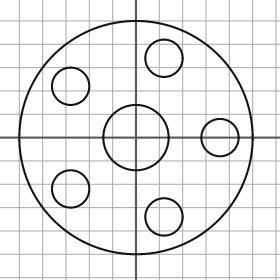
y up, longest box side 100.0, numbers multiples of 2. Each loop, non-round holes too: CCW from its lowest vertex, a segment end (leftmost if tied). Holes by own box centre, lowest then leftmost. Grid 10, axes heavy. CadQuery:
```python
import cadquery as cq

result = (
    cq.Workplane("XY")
    .moveTo(0.0, 0.0)
    .circle(50.0)
    .moveTo(12.0, -34.0)
    .circle(8.0)
    .moveTo(-28.0, -22.0)
    .circle(8.0)
    .moveTo(0.0, 0.0)
    .circle(14.0)
    .moveTo(36.0, 0.0)
    .circle(8.0)
    .moveTo(-28.0, 22.0)
    .circle(8.0)
    .moveTo(12.0, 34.0)
    .circle(8.0)
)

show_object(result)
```